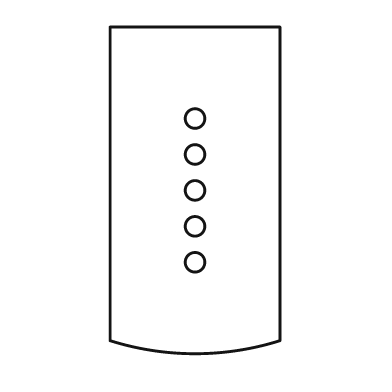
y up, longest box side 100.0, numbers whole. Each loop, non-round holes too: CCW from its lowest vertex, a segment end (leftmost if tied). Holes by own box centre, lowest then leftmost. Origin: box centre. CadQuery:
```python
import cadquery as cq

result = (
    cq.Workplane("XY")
    .moveTo(-26.0, -46.0)
    .threePointArc((0.0, -50.0), (26.0, -46.0))
    .lineTo(26.0, 50.0)
    .lineTo(-26.0, 50.0)
    .close()
    .moveTo(0.0, -22.0)
    .circle(3.0)
    .moveTo(0.0, -11.0)
    .circle(3.0)
    .moveTo(0.0, 0.0)
    .circle(3.0)
    .moveTo(0.0, 11.0)
    .circle(3.0)
    .moveTo(0.0, 22.0)
    .circle(3.0)
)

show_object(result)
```